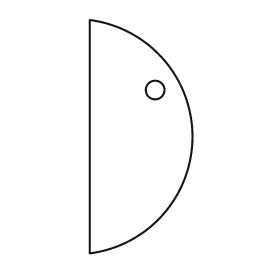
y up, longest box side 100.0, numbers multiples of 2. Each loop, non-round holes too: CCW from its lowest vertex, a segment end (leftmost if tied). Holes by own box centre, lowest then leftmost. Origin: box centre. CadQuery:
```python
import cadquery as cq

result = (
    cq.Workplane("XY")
    .moveTo(-22.0, -50.0)
    .threePointArc((22.0, 0.0), (-22.0, 50.0))
    .close()
    .moveTo(6.0, 20.0)
    .circle(4.0)
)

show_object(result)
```